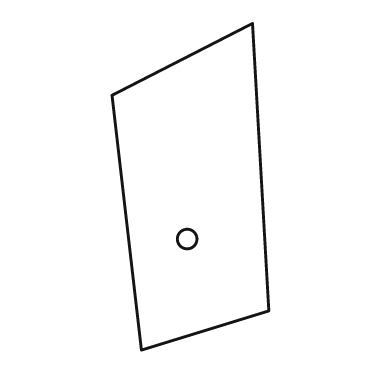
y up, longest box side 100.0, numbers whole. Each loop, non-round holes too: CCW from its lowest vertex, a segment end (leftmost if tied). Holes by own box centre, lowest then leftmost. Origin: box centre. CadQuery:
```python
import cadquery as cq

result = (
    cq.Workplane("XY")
    .moveTo(-15.0, -50.0)
    .lineTo(24.0, -38.0)
    .lineTo(19.0, 50.0)
    .lineTo(-24.0, 28.0)
    .close()
    .moveTo(-1.0, -16.0)
    .circle(3.0)
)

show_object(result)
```